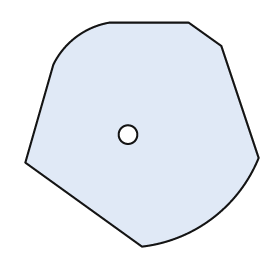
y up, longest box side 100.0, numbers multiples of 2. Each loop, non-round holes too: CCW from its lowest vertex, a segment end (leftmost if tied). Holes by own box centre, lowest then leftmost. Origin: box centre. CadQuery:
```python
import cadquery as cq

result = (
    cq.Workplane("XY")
    .moveTo(0.0, -48.0)
    .threePointArc((30.0, -36.0), (50.0, -10.0))
    .lineTo(34.0, 38.0)
    .lineTo(20.0, 48.0)
    .lineTo(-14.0, 48.0)
    .threePointArc((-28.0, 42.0), (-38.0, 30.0))
    .lineTo(-50.0, -12.0)
    .close()
    .moveTo(-6.0, 0.0)
    .circle(4.0)
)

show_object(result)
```